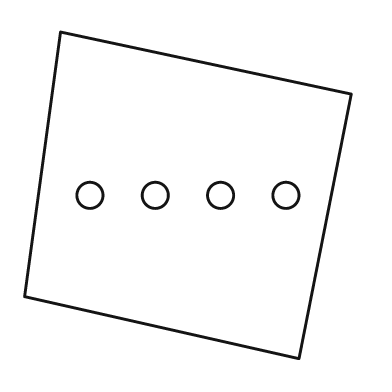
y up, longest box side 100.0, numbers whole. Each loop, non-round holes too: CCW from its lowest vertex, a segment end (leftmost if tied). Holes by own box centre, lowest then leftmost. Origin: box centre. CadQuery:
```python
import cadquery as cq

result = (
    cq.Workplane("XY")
    .moveTo(34.0, -50.0)
    .lineTo(50.0, 31.0)
    .lineTo(-39.0, 50.0)
    .lineTo(-50.0, -31.0)
    .close()
    .moveTo(-30.0, 0.0)
    .circle(4.0)
    .moveTo(-10.0, 0.0)
    .circle(4.0)
    .moveTo(10.0, 0.0)
    .circle(4.0)
    .moveTo(30.0, 0.0)
    .circle(4.0)
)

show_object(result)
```